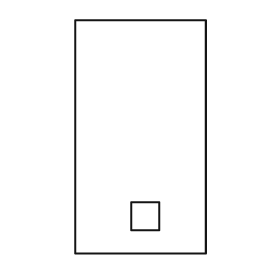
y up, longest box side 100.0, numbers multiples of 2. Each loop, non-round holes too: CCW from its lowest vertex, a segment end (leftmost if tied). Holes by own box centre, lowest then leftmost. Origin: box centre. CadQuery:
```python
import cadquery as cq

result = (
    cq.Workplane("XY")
    .moveTo(-28.0, -50.0)
    .lineTo(28.0, -50.0)
    .lineTo(28.0, 50.0)
    .lineTo(-28.0, 50.0)
    .close()
    .moveTo(-4.0, -40.0)
    .lineTo(8.0, -40.0)
    .lineTo(8.0, -28.0)
    .lineTo(-4.0, -28.0)
    .close()
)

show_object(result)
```